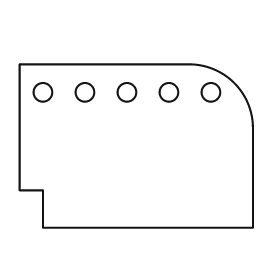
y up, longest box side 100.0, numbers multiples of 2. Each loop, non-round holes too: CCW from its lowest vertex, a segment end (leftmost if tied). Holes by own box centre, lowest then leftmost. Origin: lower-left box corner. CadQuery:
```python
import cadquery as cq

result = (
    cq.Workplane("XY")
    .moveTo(10.0, 0.0)
    .lineTo(100.0, 0.0)
    .lineTo(100.0, 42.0)
    .threePointArc((92.0, 62.0), (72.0, 70.0))
    .lineTo(0.0, 70.0)
    .lineTo(0.0, 16.0)
    .lineTo(10.0, 16.0)
    .close()
    .moveTo(10.0, 58.0)
    .circle(4.0)
    .moveTo(28.0, 58.0)
    .circle(4.0)
    .moveTo(46.0, 58.0)
    .circle(4.0)
    .moveTo(64.0, 58.0)
    .circle(4.0)
    .moveTo(82.0, 58.0)
    .circle(4.0)
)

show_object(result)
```